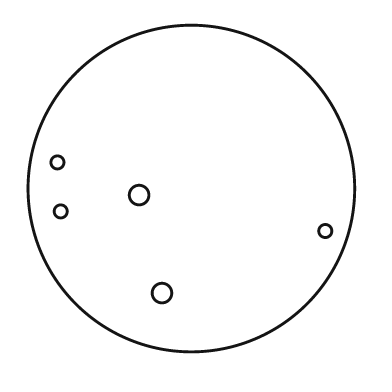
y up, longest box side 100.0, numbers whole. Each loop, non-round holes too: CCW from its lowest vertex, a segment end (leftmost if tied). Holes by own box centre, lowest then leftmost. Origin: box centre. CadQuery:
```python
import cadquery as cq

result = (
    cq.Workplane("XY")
    .moveTo(0.0, 0.0)
    .circle(50.0)
    .moveTo(-9.0, -32.0)
    .circle(3.0)
    .moveTo(41.0, -13.0)
    .circle(2.0)
    .moveTo(-40.0, -7.0)
    .circle(2.0)
    .moveTo(-16.0, -2.0)
    .circle(3.0)
    .moveTo(-41.0, 8.0)
    .circle(2.0)
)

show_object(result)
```